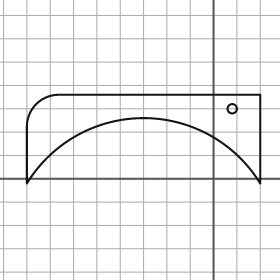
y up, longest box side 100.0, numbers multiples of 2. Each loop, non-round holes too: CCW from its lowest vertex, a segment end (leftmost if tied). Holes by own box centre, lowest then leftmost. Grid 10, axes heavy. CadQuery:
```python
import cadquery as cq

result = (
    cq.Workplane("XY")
    .moveTo(-80.0, -2.0)
    .threePointArc((-30.0, 26.0), (20.0, -2.0))
    .lineTo(20.0, 36.0)
    .lineTo(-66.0, 36.0)
    .threePointArc((-76.0, 32.0), (-80.0, 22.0))
    .close()
    .moveTo(8.0, 30.0)
    .circle(2.0)
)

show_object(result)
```